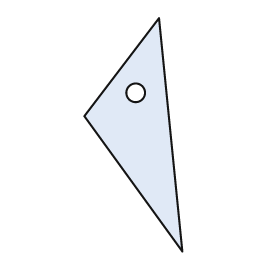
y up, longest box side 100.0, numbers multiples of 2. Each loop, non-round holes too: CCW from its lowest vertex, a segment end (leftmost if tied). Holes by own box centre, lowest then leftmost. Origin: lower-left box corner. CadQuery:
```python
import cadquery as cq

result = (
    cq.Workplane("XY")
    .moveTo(42.0, 0.0)
    .lineTo(32.0, 100.0)
    .lineTo(0.0, 58.0)
    .close()
    .moveTo(22.0, 68.0)
    .circle(4.0)
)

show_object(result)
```